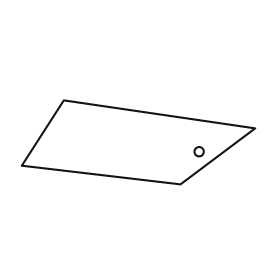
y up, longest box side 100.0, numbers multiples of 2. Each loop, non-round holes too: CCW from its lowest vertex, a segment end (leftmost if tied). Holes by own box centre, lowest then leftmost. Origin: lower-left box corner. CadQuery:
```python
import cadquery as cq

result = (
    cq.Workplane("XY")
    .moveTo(68.0, 0.0)
    .lineTo(100.0, 24.0)
    .lineTo(18.0, 36.0)
    .lineTo(0.0, 8.0)
    .close()
    .moveTo(76.0, 14.0)
    .circle(2.0)
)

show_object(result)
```